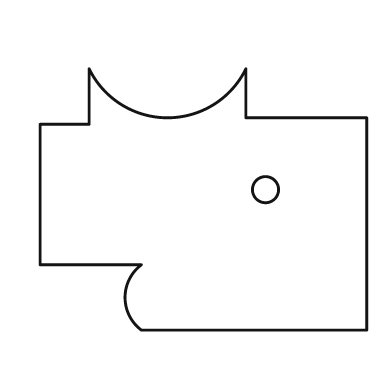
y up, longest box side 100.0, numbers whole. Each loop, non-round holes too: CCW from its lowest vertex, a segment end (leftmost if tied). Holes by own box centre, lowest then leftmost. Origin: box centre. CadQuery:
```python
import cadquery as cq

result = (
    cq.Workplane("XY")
    .moveTo(-19.0, -40.0)
    .lineTo(50.0, -40.0)
    .lineTo(50.0, 25.0)
    .lineTo(13.0, 25.0)
    .lineTo(13.0, 40.0)
    .threePointArc((-11.0, 25.0), (-35.0, 40.0))
    .lineTo(-35.0, 23.0)
    .lineTo(-50.0, 23.0)
    .lineTo(-50.0, -20.0)
    .lineTo(-19.0, -20.0)
    .threePointArc((-24.0, -30.0), (-19.0, -40.0))
    .close()
    .moveTo(19.0, 3.0)
    .circle(4.0)
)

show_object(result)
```